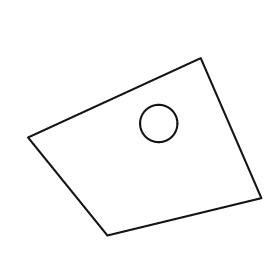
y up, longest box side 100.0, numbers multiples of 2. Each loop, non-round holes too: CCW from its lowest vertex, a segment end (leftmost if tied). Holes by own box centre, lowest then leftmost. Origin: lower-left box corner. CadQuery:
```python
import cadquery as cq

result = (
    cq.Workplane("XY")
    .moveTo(34.0, 0.0)
    .lineTo(100.0, 16.0)
    .lineTo(74.0, 76.0)
    .lineTo(0.0, 42.0)
    .close()
    .moveTo(56.0, 48.0)
    .circle(8.0)
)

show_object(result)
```